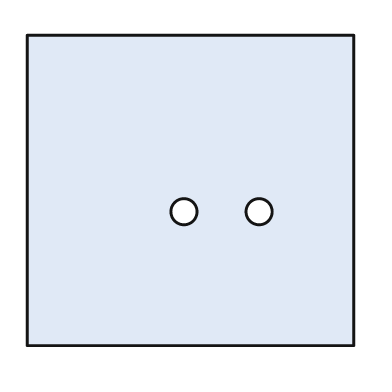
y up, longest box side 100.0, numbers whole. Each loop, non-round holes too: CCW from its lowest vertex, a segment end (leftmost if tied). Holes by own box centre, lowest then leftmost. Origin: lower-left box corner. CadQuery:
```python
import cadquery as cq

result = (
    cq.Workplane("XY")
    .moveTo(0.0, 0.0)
    .lineTo(100.0, 0.0)
    .lineTo(100.0, 95.0)
    .lineTo(0.0, 95.0)
    .close()
    .moveTo(48.0, 41.0)
    .circle(4.0)
    .moveTo(71.0, 41.0)
    .circle(4.0)
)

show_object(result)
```